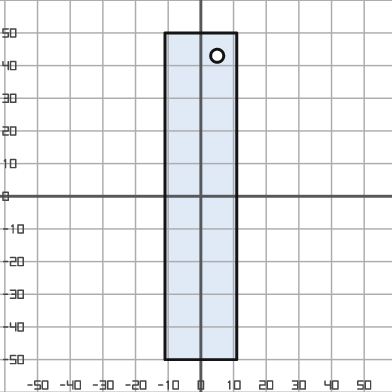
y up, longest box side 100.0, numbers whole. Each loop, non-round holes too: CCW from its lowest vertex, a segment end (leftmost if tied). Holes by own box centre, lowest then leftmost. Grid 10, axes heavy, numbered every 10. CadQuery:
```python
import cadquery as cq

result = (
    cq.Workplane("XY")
    .moveTo(-11.0, -50.0)
    .lineTo(11.0, -50.0)
    .lineTo(11.0, 50.0)
    .lineTo(-11.0, 50.0)
    .close()
    .moveTo(5.0, 43.0)
    .circle(2.0)
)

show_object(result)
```